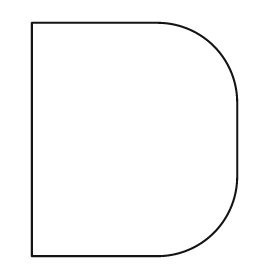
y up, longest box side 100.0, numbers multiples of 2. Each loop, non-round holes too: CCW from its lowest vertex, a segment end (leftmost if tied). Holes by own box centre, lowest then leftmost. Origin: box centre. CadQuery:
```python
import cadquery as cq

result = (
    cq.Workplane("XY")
    .moveTo(-44.0, -50.0)
    .lineTo(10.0, -50.0)
    .threePointArc((34.0, -40.0), (44.0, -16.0))
    .lineTo(44.0, 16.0)
    .threePointArc((34.0, 40.0), (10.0, 50.0))
    .lineTo(-44.0, 50.0)
    .close()
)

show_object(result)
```